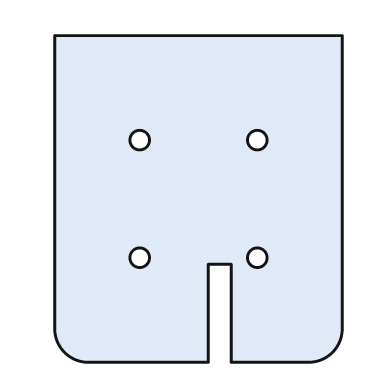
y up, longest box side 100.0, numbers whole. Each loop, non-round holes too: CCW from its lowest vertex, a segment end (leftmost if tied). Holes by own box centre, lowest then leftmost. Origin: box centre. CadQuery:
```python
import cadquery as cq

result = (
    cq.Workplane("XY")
    .moveTo(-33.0, -50.0)
    .lineTo(3.0, -50.0)
    .lineTo(3.0, -20.0)
    .lineTo(10.0, -20.0)
    .lineTo(10.0, -50.0)
    .lineTo(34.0, -50.0)
    .threePointArc((41.0, -47.0), (44.0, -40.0))
    .lineTo(44.0, 50.0)
    .lineTo(-44.0, 50.0)
    .lineTo(-44.0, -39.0)
    .threePointArc((-41.0, -47.0), (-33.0, -50.0))
    .close()
    .moveTo(-18.0, -18.0)
    .circle(3.0)
    .moveTo(18.0, -18.0)
    .circle(3.0)
    .moveTo(-18.0, 18.0)
    .circle(3.0)
    .moveTo(18.0, 18.0)
    .circle(3.0)
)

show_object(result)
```